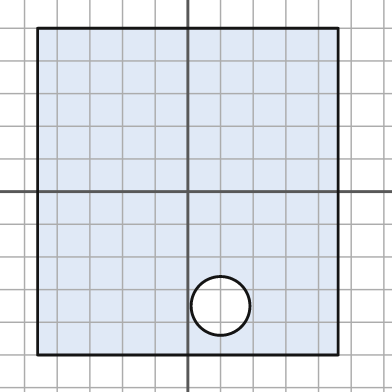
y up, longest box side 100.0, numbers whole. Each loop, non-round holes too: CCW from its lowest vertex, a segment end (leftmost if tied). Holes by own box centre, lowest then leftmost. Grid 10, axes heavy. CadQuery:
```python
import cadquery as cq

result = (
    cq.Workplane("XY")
    .moveTo(-46.0, -50.0)
    .lineTo(46.0, -50.0)
    .lineTo(46.0, 50.0)
    .lineTo(-46.0, 50.0)
    .close()
    .moveTo(10.0, -35.0)
    .circle(9.0)
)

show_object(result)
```